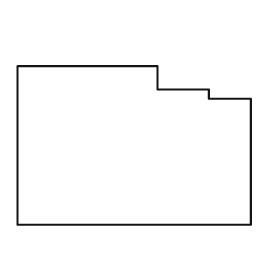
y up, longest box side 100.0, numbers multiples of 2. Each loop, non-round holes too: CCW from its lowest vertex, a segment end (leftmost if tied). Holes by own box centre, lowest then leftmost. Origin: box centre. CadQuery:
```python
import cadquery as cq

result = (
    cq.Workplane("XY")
    .moveTo(-50.0, -34.0)
    .lineTo(50.0, -34.0)
    .lineTo(50.0, 20.0)
    .lineTo(32.0, 20.0)
    .lineTo(32.0, 24.0)
    .lineTo(10.0, 24.0)
    .lineTo(10.0, 34.0)
    .lineTo(-50.0, 34.0)
    .close()
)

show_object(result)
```